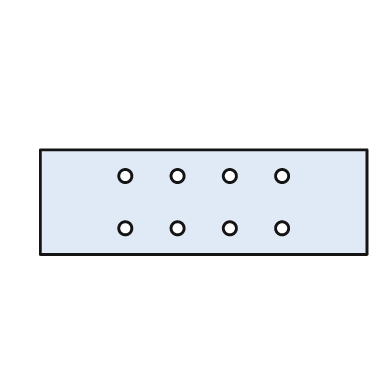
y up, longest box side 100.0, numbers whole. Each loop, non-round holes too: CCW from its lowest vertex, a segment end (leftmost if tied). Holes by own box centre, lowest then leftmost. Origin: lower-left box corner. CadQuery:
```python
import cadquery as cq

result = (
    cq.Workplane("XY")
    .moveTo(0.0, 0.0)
    .lineTo(100.0, 0.0)
    .lineTo(100.0, 32.0)
    .lineTo(0.0, 32.0)
    .close()
    .moveTo(26.0, 8.0)
    .circle(2.0)
    .moveTo(42.0, 8.0)
    .circle(2.0)
    .moveTo(58.0, 8.0)
    .circle(2.0)
    .moveTo(74.0, 8.0)
    .circle(2.0)
    .moveTo(26.0, 24.0)
    .circle(2.0)
    .moveTo(42.0, 24.0)
    .circle(2.0)
    .moveTo(58.0, 24.0)
    .circle(2.0)
    .moveTo(74.0, 24.0)
    .circle(2.0)
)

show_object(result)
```